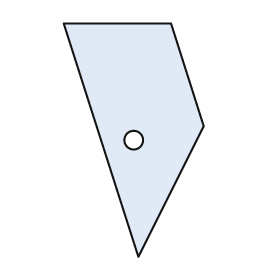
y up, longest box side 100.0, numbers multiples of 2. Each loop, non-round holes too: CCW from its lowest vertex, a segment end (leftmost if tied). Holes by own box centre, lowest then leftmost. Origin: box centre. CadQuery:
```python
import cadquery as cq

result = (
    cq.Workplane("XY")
    .moveTo(2.0, -50.0)
    .lineTo(30.0, 6.0)
    .lineTo(16.0, 50.0)
    .lineTo(-30.0, 50.0)
    .close()
    .moveTo(0.0, 0.0)
    .circle(4.0)
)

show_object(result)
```